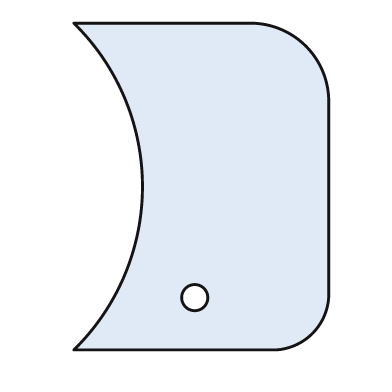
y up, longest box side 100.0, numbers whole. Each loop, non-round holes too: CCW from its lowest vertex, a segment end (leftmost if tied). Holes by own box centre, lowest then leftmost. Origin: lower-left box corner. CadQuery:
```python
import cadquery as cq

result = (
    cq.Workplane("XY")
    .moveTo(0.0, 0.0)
    .lineTo(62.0, 0.0)
    .threePointArc((73.0, 5.0), (78.0, 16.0))
    .lineTo(78.0, 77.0)
    .threePointArc((71.0, 93.0), (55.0, 100.0))
    .lineTo(0.0, 100.0)
    .threePointArc((21.0, 50.0), (0.0, 0.0))
    .close()
    .moveTo(37.0, 16.0)
    .circle(4.0)
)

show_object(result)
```